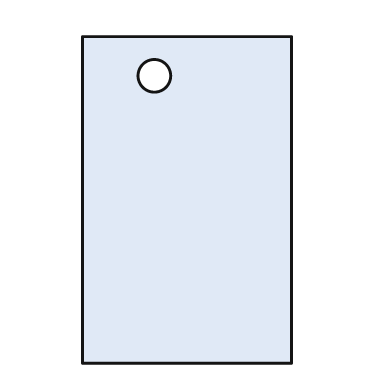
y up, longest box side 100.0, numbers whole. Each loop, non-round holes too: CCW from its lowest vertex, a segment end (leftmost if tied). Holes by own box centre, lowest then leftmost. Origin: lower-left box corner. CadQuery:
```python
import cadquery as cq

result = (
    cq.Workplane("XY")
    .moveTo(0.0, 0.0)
    .lineTo(64.0, 0.0)
    .lineTo(64.0, 100.0)
    .lineTo(0.0, 100.0)
    .close()
    .moveTo(22.0, 88.0)
    .circle(5.0)
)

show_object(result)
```